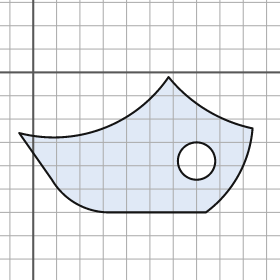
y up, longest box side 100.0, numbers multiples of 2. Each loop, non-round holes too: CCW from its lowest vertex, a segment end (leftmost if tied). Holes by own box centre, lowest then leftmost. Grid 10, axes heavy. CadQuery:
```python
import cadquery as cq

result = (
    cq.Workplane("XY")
    .moveTo(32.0, -60.0)
    .lineTo(74.0, -60.0)
    .threePointArc((88.0, -44.0), (94.0, -24.0))
    .threePointArc((74.0, -16.0), (58.0, -2.0))
    .threePointArc((30.0, -24.0), (-6.0, -26.0))
    .lineTo(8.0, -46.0)
    .threePointArc((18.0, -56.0), (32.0, -60.0))
    .close()
    .moveTo(70.0, -38.0)
    .circle(8.0)
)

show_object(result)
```